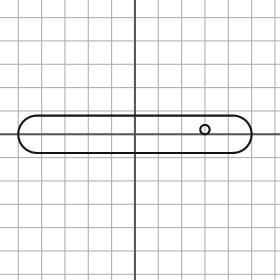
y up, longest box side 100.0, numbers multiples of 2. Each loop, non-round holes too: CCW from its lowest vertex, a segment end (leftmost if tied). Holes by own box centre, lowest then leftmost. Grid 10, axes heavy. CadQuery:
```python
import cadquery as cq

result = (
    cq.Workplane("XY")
    .moveTo(-42.0, -8.0)
    .lineTo(42.0, -8.0)
    .threePointArc((50.0, 0.0), (42.0, 8.0))
    .lineTo(-42.0, 8.0)
    .threePointArc((-50.0, 0.0), (-42.0, -8.0))
    .close()
    .moveTo(30.0, 2.0)
    .circle(2.0)
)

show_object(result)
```